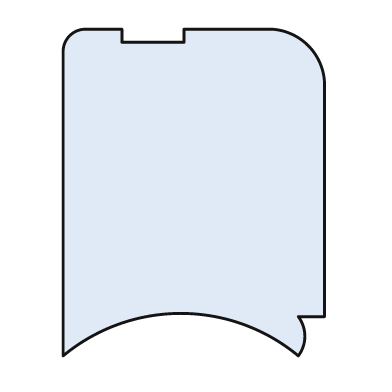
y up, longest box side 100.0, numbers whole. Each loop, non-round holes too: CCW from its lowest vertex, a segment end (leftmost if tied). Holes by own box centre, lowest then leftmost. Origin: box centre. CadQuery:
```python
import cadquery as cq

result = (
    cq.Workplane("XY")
    .moveTo(-40.0, -50.0)
    .threePointArc((-4.0, -37.0), (32.0, -50.0))
    .threePointArc((34.0, -44.0), (32.0, -38.0))
    .lineTo(40.0, -38.0)
    .lineTo(40.0, 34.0)
    .threePointArc((35.0, 45.0), (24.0, 50.0))
    .lineTo(-3.0, 50.0)
    .lineTo(-3.0, 46.0)
    .lineTo(-22.0, 46.0)
    .lineTo(-22.0, 50.0)
    .lineTo(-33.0, 50.0)
    .threePointArc((-38.0, 48.0), (-40.0, 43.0))
    .close()
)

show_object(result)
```